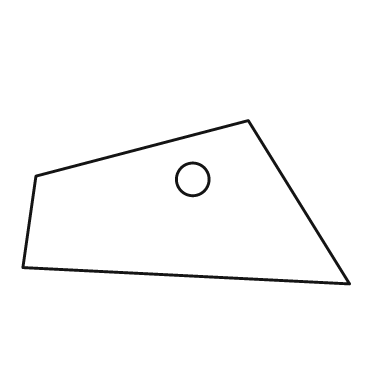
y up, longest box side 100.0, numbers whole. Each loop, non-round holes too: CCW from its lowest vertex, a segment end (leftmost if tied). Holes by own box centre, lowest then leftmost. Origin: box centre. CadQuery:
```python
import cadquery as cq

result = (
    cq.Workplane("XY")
    .moveTo(50.0, -25.0)
    .lineTo(19.0, 25.0)
    .lineTo(-46.0, 8.0)
    .lineTo(-50.0, -20.0)
    .close()
    .moveTo(2.0, 7.0)
    .circle(5.0)
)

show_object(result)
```